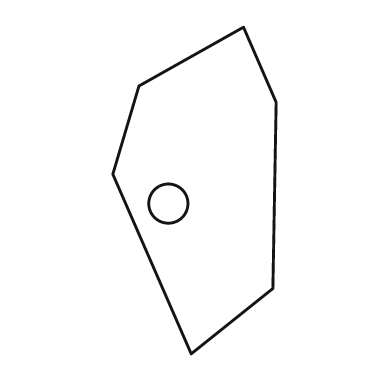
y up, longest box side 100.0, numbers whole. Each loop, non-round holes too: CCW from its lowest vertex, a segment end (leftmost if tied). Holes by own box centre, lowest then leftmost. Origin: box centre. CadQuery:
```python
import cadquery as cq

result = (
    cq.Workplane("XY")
    .moveTo(-1.0, -50.0)
    .lineTo(24.0, -30.0)
    .lineTo(25.0, 27.0)
    .lineTo(15.0, 50.0)
    .lineTo(-17.0, 32.0)
    .lineTo(-25.0, 5.0)
    .close()
    .moveTo(-8.0, -4.0)
    .circle(6.0)
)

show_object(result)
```